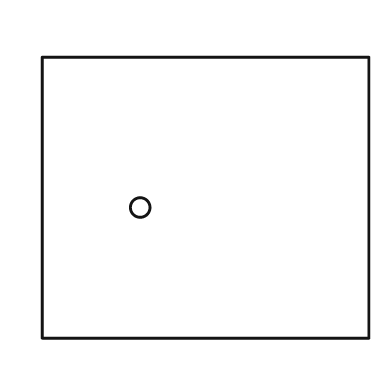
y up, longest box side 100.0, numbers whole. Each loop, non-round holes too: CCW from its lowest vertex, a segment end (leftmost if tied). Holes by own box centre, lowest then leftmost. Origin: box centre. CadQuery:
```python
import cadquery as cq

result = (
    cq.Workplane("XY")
    .moveTo(-50.0, -43.0)
    .lineTo(50.0, -43.0)
    .lineTo(50.0, 43.0)
    .lineTo(-50.0, 43.0)
    .close()
    .moveTo(-20.0, -3.0)
    .circle(3.0)
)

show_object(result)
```